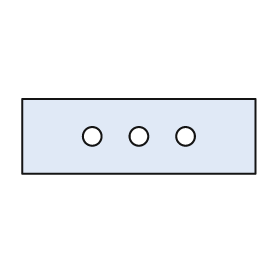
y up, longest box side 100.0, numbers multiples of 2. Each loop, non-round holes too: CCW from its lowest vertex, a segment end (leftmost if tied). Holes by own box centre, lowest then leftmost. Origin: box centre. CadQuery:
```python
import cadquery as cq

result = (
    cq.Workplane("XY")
    .moveTo(-50.0, -16.0)
    .lineTo(50.0, -16.0)
    .lineTo(50.0, 16.0)
    .lineTo(-50.0, 16.0)
    .close()
    .moveTo(-20.0, 0.0)
    .circle(4.0)
    .moveTo(0.0, 0.0)
    .circle(4.0)
    .moveTo(20.0, 0.0)
    .circle(4.0)
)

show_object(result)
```